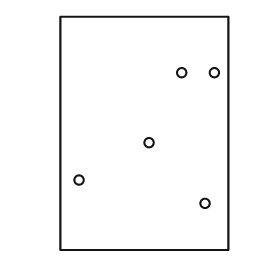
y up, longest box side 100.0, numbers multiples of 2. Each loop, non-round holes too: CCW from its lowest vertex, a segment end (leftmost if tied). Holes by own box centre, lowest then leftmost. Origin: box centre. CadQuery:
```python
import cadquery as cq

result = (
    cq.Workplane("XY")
    .moveTo(-36.0, -50.0)
    .lineTo(36.0, -50.0)
    .lineTo(36.0, 50.0)
    .lineTo(-36.0, 50.0)
    .close()
    .moveTo(26.0, -30.0)
    .circle(2.0)
    .moveTo(-28.0, -20.0)
    .circle(2.0)
    .moveTo(2.0, -4.0)
    .circle(2.0)
    .moveTo(16.0, 26.0)
    .circle(2.0)
    .moveTo(30.0, 26.0)
    .circle(2.0)
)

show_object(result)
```